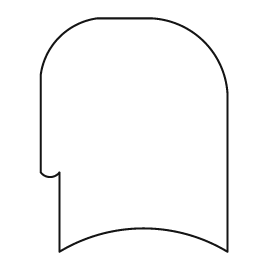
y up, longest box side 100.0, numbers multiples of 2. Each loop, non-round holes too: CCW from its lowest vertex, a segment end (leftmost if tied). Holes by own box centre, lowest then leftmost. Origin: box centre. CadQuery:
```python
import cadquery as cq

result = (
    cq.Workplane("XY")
    .moveTo(-32.0, -50.0)
    .threePointArc((4.0, -40.0), (40.0, -50.0))
    .lineTo(40.0, 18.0)
    .threePointArc((30.0, 40.0), (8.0, 50.0))
    .lineTo(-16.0, 50.0)
    .threePointArc((-32.0, 42.0), (-40.0, 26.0))
    .lineTo(-40.0, -16.0)
    .threePointArc((-36.0, -18.0), (-32.0, -16.0))
    .close()
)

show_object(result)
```